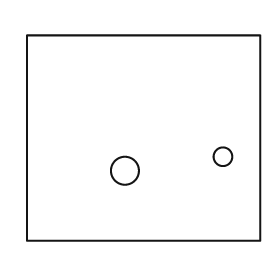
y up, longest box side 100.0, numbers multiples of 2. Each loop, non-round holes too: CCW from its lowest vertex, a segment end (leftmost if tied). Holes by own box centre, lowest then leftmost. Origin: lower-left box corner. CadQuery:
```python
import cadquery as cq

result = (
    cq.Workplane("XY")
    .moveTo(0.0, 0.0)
    .lineTo(100.0, 0.0)
    .lineTo(100.0, 88.0)
    .lineTo(0.0, 88.0)
    .close()
    .moveTo(42.0, 30.0)
    .circle(6.0)
    .moveTo(84.0, 36.0)
    .circle(4.0)
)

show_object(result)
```